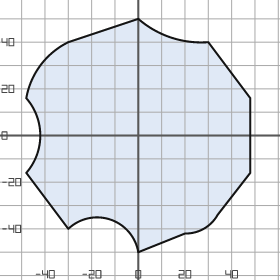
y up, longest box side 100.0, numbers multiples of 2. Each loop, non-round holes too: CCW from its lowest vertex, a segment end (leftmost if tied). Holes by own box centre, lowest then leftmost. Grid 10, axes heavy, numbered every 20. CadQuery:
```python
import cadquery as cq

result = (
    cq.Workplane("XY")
    .moveTo(0.0, -50.0)
    .lineTo(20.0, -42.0)
    .threePointArc((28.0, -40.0), (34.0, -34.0))
    .lineTo(48.0, -16.0)
    .lineTo(48.0, 16.0)
    .lineTo(30.0, 40.0)
    .threePointArc((14.0, 42.0), (0.0, 50.0))
    .lineTo(-30.0, 40.0)
    .threePointArc((-42.0, 30.0), (-48.0, 16.0))
    .threePointArc((-42.0, 0.0), (-48.0, -16.0))
    .lineTo(-30.0, -40.0)
    .threePointArc((-12.0, -36.0), (0.0, -50.0))
    .close()
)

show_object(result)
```